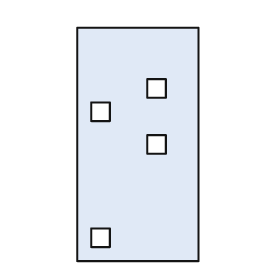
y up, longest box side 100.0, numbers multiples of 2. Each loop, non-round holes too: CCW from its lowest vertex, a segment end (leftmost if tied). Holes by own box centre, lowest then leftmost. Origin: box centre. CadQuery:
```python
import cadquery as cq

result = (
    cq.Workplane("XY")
    .moveTo(-26.0, -50.0)
    .lineTo(26.0, -50.0)
    .lineTo(26.0, 50.0)
    .lineTo(-26.0, 50.0)
    .close()
    .moveTo(-20.0, -44.0)
    .lineTo(-12.0, -44.0)
    .lineTo(-12.0, -36.0)
    .lineTo(-20.0, -36.0)
    .close()
    .moveTo(4.0, -4.0)
    .lineTo(12.0, -4.0)
    .lineTo(12.0, 4.0)
    .lineTo(4.0, 4.0)
    .close()
    .moveTo(-20.0, 10.0)
    .lineTo(-12.0, 10.0)
    .lineTo(-12.0, 18.0)
    .lineTo(-20.0, 18.0)
    .close()
    .moveTo(4.0, 20.0)
    .lineTo(12.0, 20.0)
    .lineTo(12.0, 28.0)
    .lineTo(4.0, 28.0)
    .close()
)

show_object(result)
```